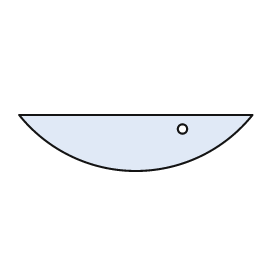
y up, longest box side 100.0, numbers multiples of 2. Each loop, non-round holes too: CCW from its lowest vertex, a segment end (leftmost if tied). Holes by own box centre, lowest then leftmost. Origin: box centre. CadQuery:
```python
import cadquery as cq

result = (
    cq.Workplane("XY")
    .moveTo(-50.0, 12.0)
    .threePointArc((0.0, -12.0), (50.0, 12.0))
    .close()
    .moveTo(20.0, 6.0)
    .circle(2.0)
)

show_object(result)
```